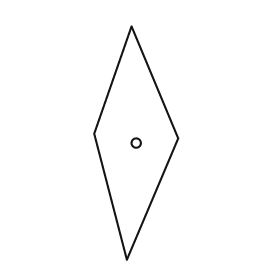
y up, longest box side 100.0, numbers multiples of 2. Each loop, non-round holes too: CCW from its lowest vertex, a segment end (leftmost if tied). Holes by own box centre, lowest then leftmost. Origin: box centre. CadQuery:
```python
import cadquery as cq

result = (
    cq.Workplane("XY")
    .moveTo(-4.0, -50.0)
    .lineTo(18.0, 2.0)
    .lineTo(-2.0, 50.0)
    .lineTo(-18.0, 4.0)
    .close()
    .moveTo(0.0, 0.0)
    .circle(2.0)
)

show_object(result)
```